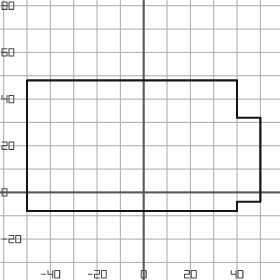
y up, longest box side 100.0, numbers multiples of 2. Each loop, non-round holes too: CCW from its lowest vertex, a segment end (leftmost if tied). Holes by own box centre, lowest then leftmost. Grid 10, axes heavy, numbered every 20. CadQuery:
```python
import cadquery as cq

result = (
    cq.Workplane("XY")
    .moveTo(-50.0, -8.0)
    .lineTo(40.0, -8.0)
    .lineTo(40.0, -4.0)
    .lineTo(50.0, -4.0)
    .lineTo(50.0, 32.0)
    .lineTo(40.0, 32.0)
    .lineTo(40.0, 48.0)
    .lineTo(-50.0, 48.0)
    .close()
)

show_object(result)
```